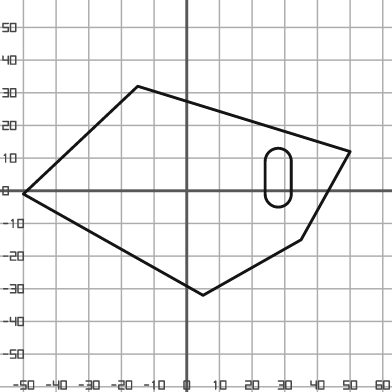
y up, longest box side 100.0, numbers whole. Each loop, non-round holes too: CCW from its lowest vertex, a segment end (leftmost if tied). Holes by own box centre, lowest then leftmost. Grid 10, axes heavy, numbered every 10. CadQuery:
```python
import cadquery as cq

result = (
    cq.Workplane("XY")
    .moveTo(5.0, -32.0)
    .lineTo(35.0, -15.0)
    .lineTo(50.0, 12.0)
    .lineTo(-15.0, 32.0)
    .lineTo(-50.0, -1.0)
    .close()
    .moveTo(24.0, -1.0)
    .threePointArc((28.0, -5.0), (32.0, -1.0))
    .lineTo(32.0, 9.0)
    .threePointArc((28.0, 13.0), (24.0, 9.0))
    .close()
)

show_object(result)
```